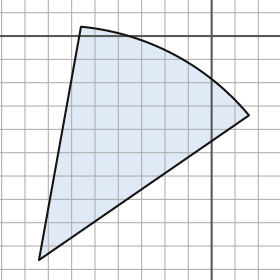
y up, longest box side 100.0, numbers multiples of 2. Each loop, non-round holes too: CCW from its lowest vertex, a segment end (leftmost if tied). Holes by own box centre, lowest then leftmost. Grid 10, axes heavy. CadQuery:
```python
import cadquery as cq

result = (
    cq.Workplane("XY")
    .moveTo(-74.0, -96.0)
    .lineTo(16.0, -34.0)
    .threePointArc((-16.0, -8.0), (-56.0, 4.0))
    .close()
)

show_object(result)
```